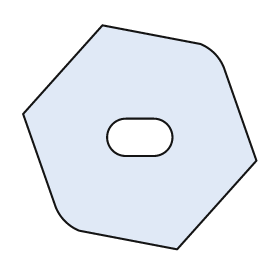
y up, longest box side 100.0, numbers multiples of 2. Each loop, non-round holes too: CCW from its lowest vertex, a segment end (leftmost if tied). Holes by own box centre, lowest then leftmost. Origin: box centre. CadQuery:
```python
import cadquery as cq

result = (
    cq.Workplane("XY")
    .moveTo(16.0, -48.0)
    .lineTo(50.0, -10.0)
    .lineTo(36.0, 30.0)
    .threePointArc((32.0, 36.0), (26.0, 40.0))
    .lineTo(-16.0, 48.0)
    .lineTo(-50.0, 10.0)
    .lineTo(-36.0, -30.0)
    .threePointArc((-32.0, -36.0), (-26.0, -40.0))
    .close()
    .moveTo(-6.0, -8.0)
    .lineTo(6.0, -8.0)
    .threePointArc((14.0, 0.0), (6.0, 8.0))
    .lineTo(-6.0, 8.0)
    .threePointArc((-14.0, 0.0), (-6.0, -8.0))
    .close()
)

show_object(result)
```